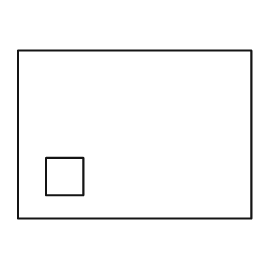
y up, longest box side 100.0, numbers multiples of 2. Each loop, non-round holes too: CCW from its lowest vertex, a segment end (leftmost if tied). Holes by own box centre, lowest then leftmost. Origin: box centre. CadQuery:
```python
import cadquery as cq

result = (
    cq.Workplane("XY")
    .moveTo(-50.0, -36.0)
    .lineTo(50.0, -36.0)
    .lineTo(50.0, 36.0)
    .lineTo(-50.0, 36.0)
    .close()
    .moveTo(-38.0, -26.0)
    .lineTo(-22.0, -26.0)
    .lineTo(-22.0, -10.0)
    .lineTo(-38.0, -10.0)
    .close()
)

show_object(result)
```